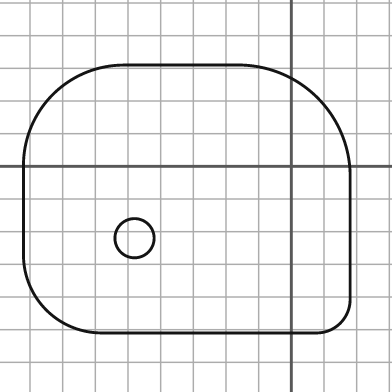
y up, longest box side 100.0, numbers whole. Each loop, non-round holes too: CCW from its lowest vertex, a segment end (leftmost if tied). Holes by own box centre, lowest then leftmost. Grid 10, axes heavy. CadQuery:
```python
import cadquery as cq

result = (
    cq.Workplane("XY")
    .moveTo(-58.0, -51.0)
    .lineTo(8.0, -51.0)
    .threePointArc((15.0, -48.0), (18.0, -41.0))
    .lineTo(18.0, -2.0)
    .threePointArc((8.0, 21.0), (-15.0, 31.0))
    .lineTo(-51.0, 31.0)
    .threePointArc((-73.0, 22.0), (-82.0, 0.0))
    .lineTo(-82.0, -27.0)
    .threePointArc((-75.0, -44.0), (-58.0, -51.0))
    .close()
    .moveTo(-48.0, -22.0)
    .circle(6.0)
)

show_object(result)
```